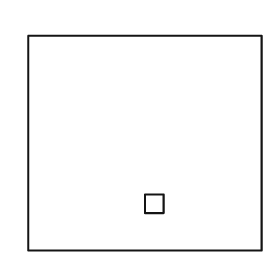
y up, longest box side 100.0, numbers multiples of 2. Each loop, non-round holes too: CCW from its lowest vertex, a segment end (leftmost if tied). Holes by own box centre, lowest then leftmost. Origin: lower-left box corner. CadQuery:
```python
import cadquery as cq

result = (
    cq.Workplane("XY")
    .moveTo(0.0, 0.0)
    .lineTo(100.0, 0.0)
    .lineTo(100.0, 92.0)
    .lineTo(0.0, 92.0)
    .close()
    .moveTo(50.0, 16.0)
    .lineTo(58.0, 16.0)
    .lineTo(58.0, 24.0)
    .lineTo(50.0, 24.0)
    .close()
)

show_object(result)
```